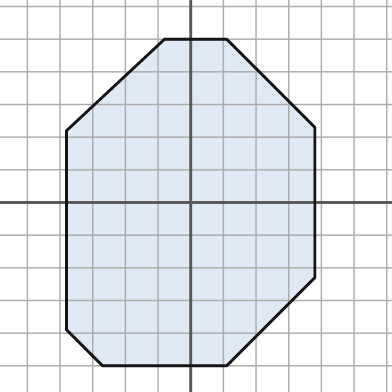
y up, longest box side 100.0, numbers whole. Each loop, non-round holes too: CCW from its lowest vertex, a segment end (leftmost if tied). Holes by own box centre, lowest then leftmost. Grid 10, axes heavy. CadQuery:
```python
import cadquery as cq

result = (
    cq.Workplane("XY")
    .moveTo(-27.0, -50.0)
    .lineTo(11.0, -50.0)
    .lineTo(38.0, -23.0)
    .lineTo(38.0, 23.0)
    .lineTo(11.0, 50.0)
    .lineTo(-8.0, 50.0)
    .lineTo(-38.0, 22.0)
    .lineTo(-38.0, -39.0)
    .close()
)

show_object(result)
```